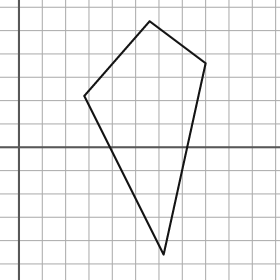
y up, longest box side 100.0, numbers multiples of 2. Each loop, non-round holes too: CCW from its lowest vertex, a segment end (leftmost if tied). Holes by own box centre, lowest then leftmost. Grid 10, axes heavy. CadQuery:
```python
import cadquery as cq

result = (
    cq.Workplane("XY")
    .moveTo(62.0, -46.0)
    .lineTo(80.0, 36.0)
    .lineTo(56.0, 54.0)
    .lineTo(28.0, 22.0)
    .close()
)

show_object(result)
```